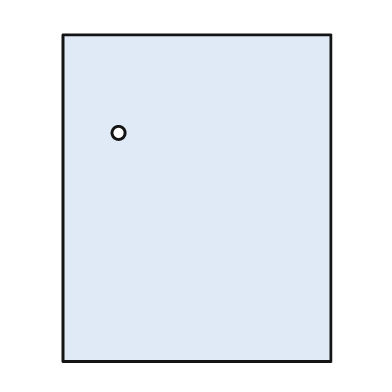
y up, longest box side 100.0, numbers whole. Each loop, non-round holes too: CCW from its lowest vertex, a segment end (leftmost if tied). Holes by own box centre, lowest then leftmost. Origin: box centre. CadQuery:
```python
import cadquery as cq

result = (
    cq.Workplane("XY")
    .moveTo(-41.0, -50.0)
    .lineTo(41.0, -50.0)
    .lineTo(41.0, 50.0)
    .lineTo(-41.0, 50.0)
    .close()
    .moveTo(-24.0, 20.0)
    .circle(2.0)
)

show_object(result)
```